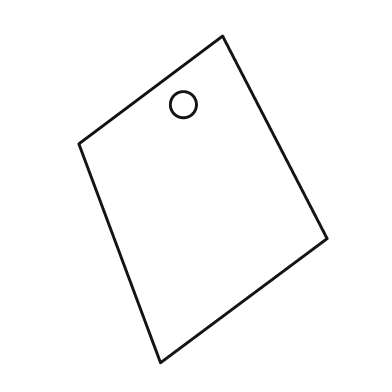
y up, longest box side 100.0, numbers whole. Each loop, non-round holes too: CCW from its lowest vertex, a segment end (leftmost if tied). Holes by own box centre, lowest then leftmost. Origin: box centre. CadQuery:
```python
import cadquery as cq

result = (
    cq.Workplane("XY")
    .moveTo(-13.0, -50.0)
    .lineTo(38.0, -12.0)
    .lineTo(6.0, 50.0)
    .lineTo(-38.0, 17.0)
    .close()
    .moveTo(-6.0, 29.0)
    .circle(4.0)
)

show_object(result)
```